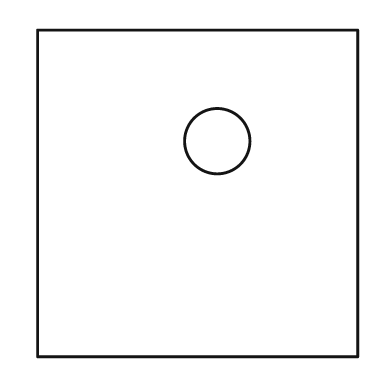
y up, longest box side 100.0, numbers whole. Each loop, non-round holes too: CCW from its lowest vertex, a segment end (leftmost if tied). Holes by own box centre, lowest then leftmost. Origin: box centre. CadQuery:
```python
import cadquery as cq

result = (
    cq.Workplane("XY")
    .moveTo(-49.0, -50.0)
    .lineTo(49.0, -50.0)
    .lineTo(49.0, 50.0)
    .lineTo(-49.0, 50.0)
    .close()
    .moveTo(6.0, 16.0)
    .circle(10.0)
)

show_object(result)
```